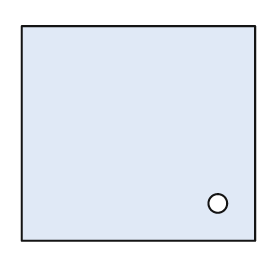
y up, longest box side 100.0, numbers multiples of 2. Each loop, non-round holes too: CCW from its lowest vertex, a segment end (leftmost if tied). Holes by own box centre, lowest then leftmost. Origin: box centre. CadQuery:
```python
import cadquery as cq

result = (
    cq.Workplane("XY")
    .moveTo(-50.0, -46.0)
    .lineTo(50.0, -46.0)
    .lineTo(50.0, 46.0)
    .lineTo(-50.0, 46.0)
    .close()
    .moveTo(34.0, -30.0)
    .circle(4.0)
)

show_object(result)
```